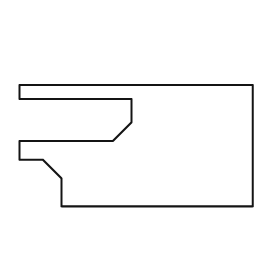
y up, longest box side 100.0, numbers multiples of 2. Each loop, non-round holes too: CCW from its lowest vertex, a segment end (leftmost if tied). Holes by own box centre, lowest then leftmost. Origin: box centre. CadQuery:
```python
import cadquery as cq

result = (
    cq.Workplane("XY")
    .moveTo(-32.0, -26.0)
    .lineTo(50.0, -26.0)
    .lineTo(50.0, 26.0)
    .lineTo(-50.0, 26.0)
    .lineTo(-50.0, 20.0)
    .lineTo(-2.0, 20.0)
    .lineTo(-2.0, 10.0)
    .lineTo(-10.0, 2.0)
    .lineTo(-50.0, 2.0)
    .lineTo(-50.0, -6.0)
    .lineTo(-40.0, -6.0)
    .lineTo(-32.0, -14.0)
    .close()
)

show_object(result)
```